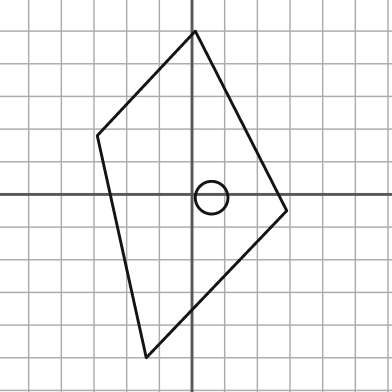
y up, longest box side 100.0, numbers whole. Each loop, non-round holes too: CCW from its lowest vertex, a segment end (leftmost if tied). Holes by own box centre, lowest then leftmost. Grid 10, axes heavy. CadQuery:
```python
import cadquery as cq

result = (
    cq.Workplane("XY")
    .moveTo(-14.0, -50.0)
    .lineTo(29.0, -5.0)
    .lineTo(1.0, 50.0)
    .lineTo(-29.0, 18.0)
    .close()
    .moveTo(6.0, -1.0)
    .circle(5.0)
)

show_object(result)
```